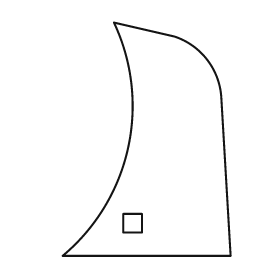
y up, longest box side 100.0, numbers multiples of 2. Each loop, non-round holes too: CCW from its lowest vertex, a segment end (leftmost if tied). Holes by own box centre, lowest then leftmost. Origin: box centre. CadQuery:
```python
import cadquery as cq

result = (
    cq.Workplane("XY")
    .moveTo(-36.0, -50.0)
    .lineTo(36.0, -50.0)
    .lineTo(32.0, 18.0)
    .threePointArc((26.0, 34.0), (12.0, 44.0))
    .lineTo(-14.0, 50.0)
    .threePointArc((-8.0, -4.0), (-36.0, -50.0))
    .close()
    .moveTo(-10.0, -40.0)
    .lineTo(-2.0, -40.0)
    .lineTo(-2.0, -32.0)
    .lineTo(-10.0, -32.0)
    .close()
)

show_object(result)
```